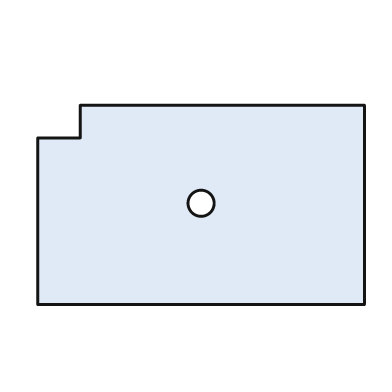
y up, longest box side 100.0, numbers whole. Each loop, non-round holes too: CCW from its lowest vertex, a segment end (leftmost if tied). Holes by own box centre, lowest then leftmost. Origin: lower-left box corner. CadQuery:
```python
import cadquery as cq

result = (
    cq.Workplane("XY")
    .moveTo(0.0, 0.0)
    .lineTo(100.0, 0.0)
    .lineTo(100.0, 61.0)
    .lineTo(13.0, 61.0)
    .lineTo(13.0, 51.0)
    .lineTo(0.0, 51.0)
    .close()
    .moveTo(50.0, 31.0)
    .circle(4.0)
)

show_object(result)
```